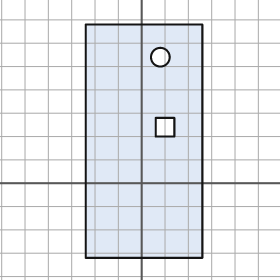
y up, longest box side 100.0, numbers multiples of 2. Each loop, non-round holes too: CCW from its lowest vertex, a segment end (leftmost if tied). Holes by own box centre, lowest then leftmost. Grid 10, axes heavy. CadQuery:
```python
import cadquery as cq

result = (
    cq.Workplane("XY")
    .moveTo(-24.0, -32.0)
    .lineTo(26.0, -32.0)
    .lineTo(26.0, 68.0)
    .lineTo(-24.0, 68.0)
    .close()
    .moveTo(6.0, 20.0)
    .lineTo(14.0, 20.0)
    .lineTo(14.0, 28.0)
    .lineTo(6.0, 28.0)
    .close()
    .moveTo(8.0, 54.0)
    .circle(4.0)
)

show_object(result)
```